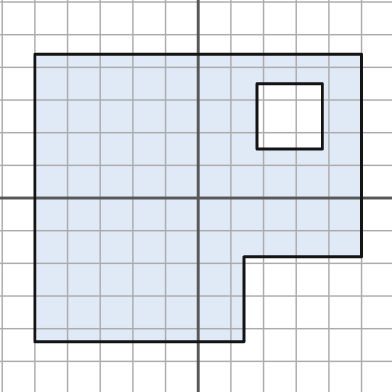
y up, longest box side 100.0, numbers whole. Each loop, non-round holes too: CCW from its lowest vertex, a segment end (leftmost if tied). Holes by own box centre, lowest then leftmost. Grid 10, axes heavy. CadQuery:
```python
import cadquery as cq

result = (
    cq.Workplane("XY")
    .moveTo(-50.0, -44.0)
    .lineTo(14.0, -44.0)
    .lineTo(14.0, -18.0)
    .lineTo(50.0, -18.0)
    .lineTo(50.0, 44.0)
    .lineTo(-50.0, 44.0)
    .close()
    .moveTo(18.0, 15.0)
    .lineTo(38.0, 15.0)
    .lineTo(38.0, 35.0)
    .lineTo(18.0, 35.0)
    .close()
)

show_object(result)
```